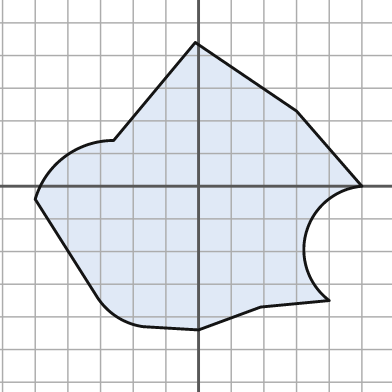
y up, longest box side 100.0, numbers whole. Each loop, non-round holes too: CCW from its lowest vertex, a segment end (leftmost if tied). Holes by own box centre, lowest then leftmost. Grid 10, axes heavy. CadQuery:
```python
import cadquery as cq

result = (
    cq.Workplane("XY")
    .moveTo(0.0, -44.0)
    .lineTo(19.0, -37.0)
    .lineTo(40.0, -35.0)
    .threePointArc((33.0, -14.0), (50.0, 0.0))
    .lineTo(30.0, 23.0)
    .lineTo(-1.0, 44.0)
    .lineTo(-26.0, 14.0)
    .threePointArc((-41.0, 9.0), (-50.0, -4.0))
    .lineTo(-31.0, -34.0)
    .threePointArc((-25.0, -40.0), (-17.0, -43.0))
    .close()
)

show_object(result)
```